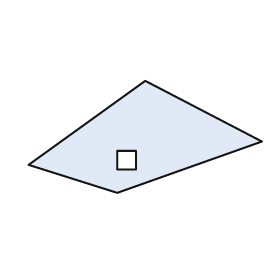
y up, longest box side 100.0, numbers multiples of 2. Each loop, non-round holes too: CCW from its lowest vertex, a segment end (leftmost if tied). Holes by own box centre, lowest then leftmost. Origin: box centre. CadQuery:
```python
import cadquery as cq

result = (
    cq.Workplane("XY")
    .moveTo(-12.0, -24.0)
    .lineTo(50.0, -2.0)
    .lineTo(0.0, 24.0)
    .lineTo(-50.0, -12.0)
    .close()
    .moveTo(-12.0, -14.0)
    .lineTo(-4.0, -14.0)
    .lineTo(-4.0, -6.0)
    .lineTo(-12.0, -6.0)
    .close()
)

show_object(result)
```